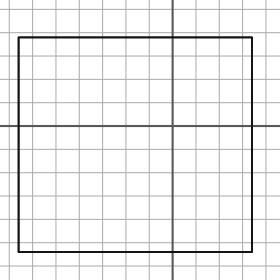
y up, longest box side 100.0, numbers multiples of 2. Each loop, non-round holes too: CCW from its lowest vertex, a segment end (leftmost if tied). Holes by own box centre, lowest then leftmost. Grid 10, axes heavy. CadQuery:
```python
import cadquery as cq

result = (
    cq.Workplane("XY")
    .moveTo(-66.0, -54.0)
    .lineTo(34.0, -54.0)
    .lineTo(34.0, 38.0)
    .lineTo(-66.0, 38.0)
    .close()
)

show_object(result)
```